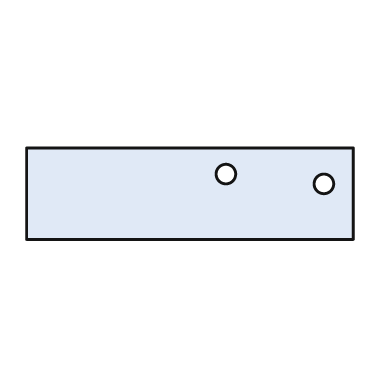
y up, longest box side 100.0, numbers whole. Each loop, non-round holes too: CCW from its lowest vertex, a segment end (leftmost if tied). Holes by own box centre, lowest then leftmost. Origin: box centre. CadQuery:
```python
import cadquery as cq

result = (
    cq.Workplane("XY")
    .moveTo(-50.0, -14.0)
    .lineTo(50.0, -14.0)
    .lineTo(50.0, 14.0)
    .lineTo(-50.0, 14.0)
    .close()
    .moveTo(41.0, 3.0)
    .circle(3.0)
    .moveTo(11.0, 6.0)
    .circle(3.0)
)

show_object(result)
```